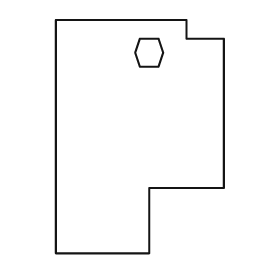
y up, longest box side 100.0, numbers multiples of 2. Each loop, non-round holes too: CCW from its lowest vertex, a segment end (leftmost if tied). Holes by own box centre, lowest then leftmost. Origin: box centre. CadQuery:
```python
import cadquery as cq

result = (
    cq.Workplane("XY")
    .moveTo(-36.0, -50.0)
    .lineTo(4.0, -50.0)
    .lineTo(4.0, -22.0)
    .lineTo(36.0, -22.0)
    .lineTo(36.0, 42.0)
    .lineTo(20.0, 42.0)
    .lineTo(20.0, 50.0)
    .lineTo(-36.0, 50.0)
    .close()
    .moveTo(0.0, 30.0)
    .lineTo(8.0, 30.0)
    .lineTo(10.0, 36.0)
    .lineTo(8.0, 42.0)
    .lineTo(0.0, 42.0)
    .lineTo(-2.0, 36.0)
    .close()
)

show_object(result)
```